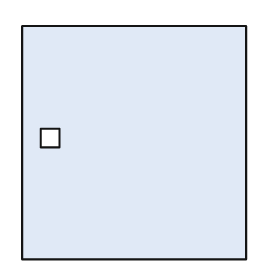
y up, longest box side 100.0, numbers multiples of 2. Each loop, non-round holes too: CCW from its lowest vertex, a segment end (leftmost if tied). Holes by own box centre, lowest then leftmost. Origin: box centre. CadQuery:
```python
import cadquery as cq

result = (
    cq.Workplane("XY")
    .moveTo(-48.0, -50.0)
    .lineTo(48.0, -50.0)
    .lineTo(48.0, 50.0)
    .lineTo(-48.0, 50.0)
    .close()
    .moveTo(-40.0, -2.0)
    .lineTo(-32.0, -2.0)
    .lineTo(-32.0, 6.0)
    .lineTo(-40.0, 6.0)
    .close()
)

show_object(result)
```